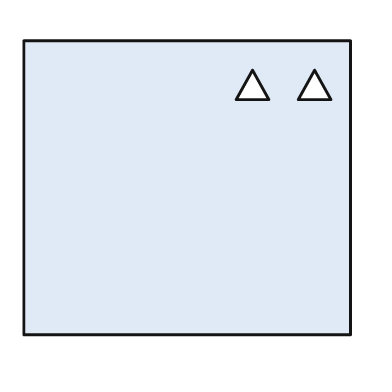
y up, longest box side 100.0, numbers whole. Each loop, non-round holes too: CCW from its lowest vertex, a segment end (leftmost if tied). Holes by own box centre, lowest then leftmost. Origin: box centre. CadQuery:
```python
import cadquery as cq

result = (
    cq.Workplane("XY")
    .moveTo(-50.0, -45.0)
    .lineTo(50.0, -45.0)
    .lineTo(50.0, 45.0)
    .lineTo(-50.0, 45.0)
    .close()
    .moveTo(15.0, 27.0)
    .lineTo(25.0, 27.0)
    .lineTo(20.0, 36.0)
    .close()
    .moveTo(34.0, 27.0)
    .lineTo(44.0, 27.0)
    .lineTo(39.0, 36.0)
    .close()
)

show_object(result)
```